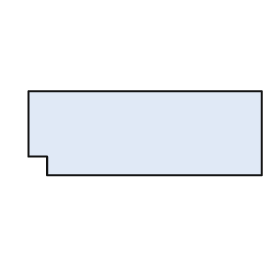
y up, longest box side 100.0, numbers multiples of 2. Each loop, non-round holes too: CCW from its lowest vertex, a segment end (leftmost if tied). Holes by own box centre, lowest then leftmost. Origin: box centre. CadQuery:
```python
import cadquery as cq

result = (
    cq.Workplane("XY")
    .moveTo(-42.0, -18.0)
    .lineTo(50.0, -18.0)
    .lineTo(50.0, 18.0)
    .lineTo(-50.0, 18.0)
    .lineTo(-50.0, -10.0)
    .lineTo(-42.0, -10.0)
    .close()
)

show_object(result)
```